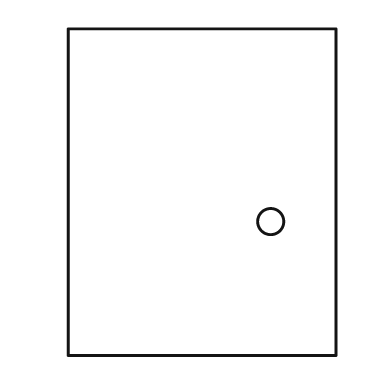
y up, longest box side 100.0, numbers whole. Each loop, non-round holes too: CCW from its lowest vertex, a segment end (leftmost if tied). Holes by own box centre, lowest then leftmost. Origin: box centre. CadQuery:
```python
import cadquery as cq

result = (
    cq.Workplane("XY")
    .moveTo(-41.0, -50.0)
    .lineTo(41.0, -50.0)
    .lineTo(41.0, 50.0)
    .lineTo(-41.0, 50.0)
    .close()
    .moveTo(21.0, -9.0)
    .circle(4.0)
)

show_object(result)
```